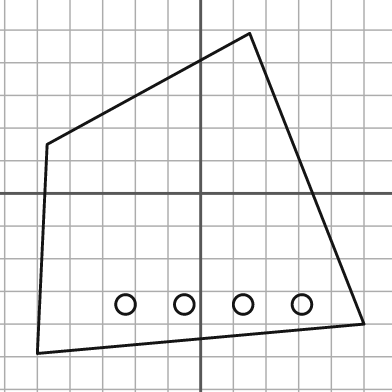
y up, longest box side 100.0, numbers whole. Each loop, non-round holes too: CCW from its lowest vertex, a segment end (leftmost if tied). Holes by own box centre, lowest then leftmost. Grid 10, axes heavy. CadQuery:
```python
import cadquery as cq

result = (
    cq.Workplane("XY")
    .moveTo(-50.0, -49.0)
    .lineTo(50.0, -40.0)
    .lineTo(15.0, 49.0)
    .lineTo(-47.0, 15.0)
    .close()
    .moveTo(-23.0, -34.0)
    .circle(3.0)
    .moveTo(-5.0, -34.0)
    .circle(3.0)
    .moveTo(13.0, -34.0)
    .circle(3.0)
    .moveTo(31.0, -34.0)
    .circle(3.0)
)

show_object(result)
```